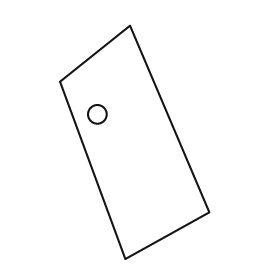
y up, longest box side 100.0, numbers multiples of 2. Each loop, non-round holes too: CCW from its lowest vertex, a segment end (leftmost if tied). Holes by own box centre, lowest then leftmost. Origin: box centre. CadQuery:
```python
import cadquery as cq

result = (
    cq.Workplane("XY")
    .moveTo(-4.0, -50.0)
    .lineTo(32.0, -30.0)
    .lineTo(-2.0, 50.0)
    .lineTo(-32.0, 26.0)
    .close()
    .moveTo(-16.0, 12.0)
    .circle(4.0)
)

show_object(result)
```